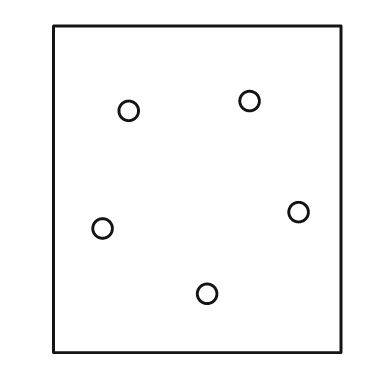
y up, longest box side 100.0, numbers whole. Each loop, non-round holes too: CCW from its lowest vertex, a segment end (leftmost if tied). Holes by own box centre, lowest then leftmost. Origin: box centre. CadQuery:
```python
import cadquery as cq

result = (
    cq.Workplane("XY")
    .moveTo(-44.0, -50.0)
    .lineTo(44.0, -50.0)
    .lineTo(44.0, 50.0)
    .lineTo(-44.0, 50.0)
    .close()
    .moveTo(3.0, -32.0)
    .circle(3.0)
    .moveTo(-29.0, -12.0)
    .circle(3.0)
    .moveTo(31.0, -7.0)
    .circle(3.0)
    .moveTo(-21.0, 24.0)
    .circle(3.0)
    .moveTo(16.0, 27.0)
    .circle(3.0)
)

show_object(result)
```